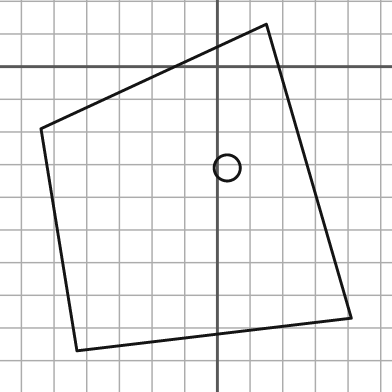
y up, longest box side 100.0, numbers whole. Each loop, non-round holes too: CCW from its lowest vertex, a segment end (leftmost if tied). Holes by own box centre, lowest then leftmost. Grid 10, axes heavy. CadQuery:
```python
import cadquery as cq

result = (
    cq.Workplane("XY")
    .moveTo(-43.0, -87.0)
    .lineTo(41.0, -77.0)
    .lineTo(15.0, 13.0)
    .lineTo(-54.0, -19.0)
    .close()
    .moveTo(3.0, -31.0)
    .circle(4.0)
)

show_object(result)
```